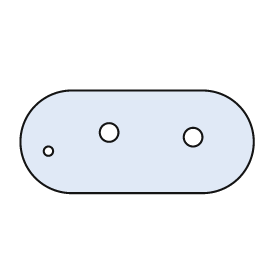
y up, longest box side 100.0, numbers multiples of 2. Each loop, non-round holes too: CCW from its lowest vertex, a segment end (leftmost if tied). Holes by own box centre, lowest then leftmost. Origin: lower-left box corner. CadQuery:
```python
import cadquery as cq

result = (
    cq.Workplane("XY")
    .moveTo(22.0, 0.0)
    .lineTo(78.0, 0.0)
    .threePointArc((100.0, 22.0), (78.0, 44.0))
    .lineTo(22.0, 44.0)
    .threePointArc((0.0, 22.0), (22.0, 0.0))
    .close()
    .moveTo(12.0, 18.0)
    .circle(2.0)
    .moveTo(74.0, 24.0)
    .circle(4.0)
    .moveTo(38.0, 26.0)
    .circle(4.0)
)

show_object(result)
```